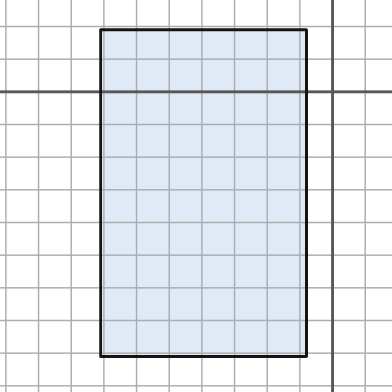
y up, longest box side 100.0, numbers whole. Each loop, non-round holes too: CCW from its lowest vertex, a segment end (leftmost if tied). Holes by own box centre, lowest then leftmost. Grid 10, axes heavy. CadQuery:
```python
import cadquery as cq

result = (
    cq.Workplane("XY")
    .moveTo(-71.0, -81.0)
    .lineTo(-8.0, -81.0)
    .lineTo(-8.0, 19.0)
    .lineTo(-71.0, 19.0)
    .close()
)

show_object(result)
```